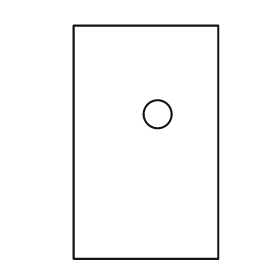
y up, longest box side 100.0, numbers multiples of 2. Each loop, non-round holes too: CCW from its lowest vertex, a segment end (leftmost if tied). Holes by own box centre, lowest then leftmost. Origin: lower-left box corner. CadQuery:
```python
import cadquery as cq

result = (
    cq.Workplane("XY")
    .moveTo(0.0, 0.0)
    .lineTo(62.0, 0.0)
    .lineTo(62.0, 100.0)
    .lineTo(0.0, 100.0)
    .close()
    .moveTo(36.0, 62.0)
    .circle(6.0)
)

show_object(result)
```